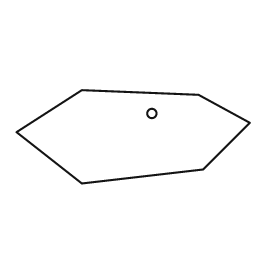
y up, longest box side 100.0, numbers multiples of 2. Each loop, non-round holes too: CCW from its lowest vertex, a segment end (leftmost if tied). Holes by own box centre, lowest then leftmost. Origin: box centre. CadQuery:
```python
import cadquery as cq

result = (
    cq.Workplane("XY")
    .moveTo(-22.0, -20.0)
    .lineTo(30.0, -14.0)
    .lineTo(50.0, 6.0)
    .lineTo(28.0, 18.0)
    .lineTo(-22.0, 20.0)
    .lineTo(-50.0, 2.0)
    .close()
    .moveTo(8.0, 10.0)
    .circle(2.0)
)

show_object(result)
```